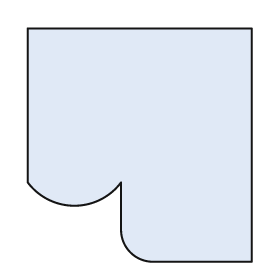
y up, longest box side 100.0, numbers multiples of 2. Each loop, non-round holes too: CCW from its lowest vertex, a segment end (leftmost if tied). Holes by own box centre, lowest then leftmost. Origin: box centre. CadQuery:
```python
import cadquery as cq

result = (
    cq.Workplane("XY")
    .moveTo(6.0, -50.0)
    .lineTo(48.0, -50.0)
    .lineTo(48.0, 50.0)
    .lineTo(-48.0, 50.0)
    .lineTo(-48.0, -16.0)
    .threePointArc((-28.0, -26.0), (-8.0, -16.0))
    .lineTo(-8.0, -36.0)
    .threePointArc((-4.0, -46.0), (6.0, -50.0))
    .close()
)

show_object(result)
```